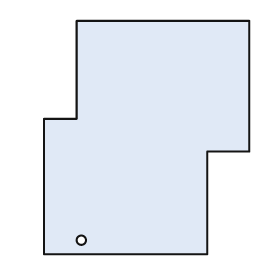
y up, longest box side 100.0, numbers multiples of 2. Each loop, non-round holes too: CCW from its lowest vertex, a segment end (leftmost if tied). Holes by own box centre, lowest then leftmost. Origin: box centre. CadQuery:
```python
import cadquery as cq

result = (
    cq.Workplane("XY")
    .moveTo(-44.0, -50.0)
    .lineTo(26.0, -50.0)
    .lineTo(26.0, -6.0)
    .lineTo(44.0, -6.0)
    .lineTo(44.0, 50.0)
    .lineTo(-30.0, 50.0)
    .lineTo(-30.0, 8.0)
    .lineTo(-44.0, 8.0)
    .close()
    .moveTo(-28.0, -44.0)
    .circle(2.0)
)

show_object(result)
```